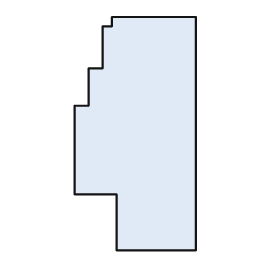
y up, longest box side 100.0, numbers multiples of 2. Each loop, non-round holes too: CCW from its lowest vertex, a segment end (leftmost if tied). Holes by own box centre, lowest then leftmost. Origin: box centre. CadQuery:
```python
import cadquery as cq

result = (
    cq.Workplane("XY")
    .moveTo(-8.0, -50.0)
    .lineTo(26.0, -50.0)
    .lineTo(26.0, 50.0)
    .lineTo(-10.0, 50.0)
    .lineTo(-10.0, 46.0)
    .lineTo(-14.0, 46.0)
    .lineTo(-14.0, 28.0)
    .lineTo(-20.0, 28.0)
    .lineTo(-20.0, 12.0)
    .lineTo(-26.0, 12.0)
    .lineTo(-26.0, -26.0)
    .lineTo(-8.0, -26.0)
    .close()
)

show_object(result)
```